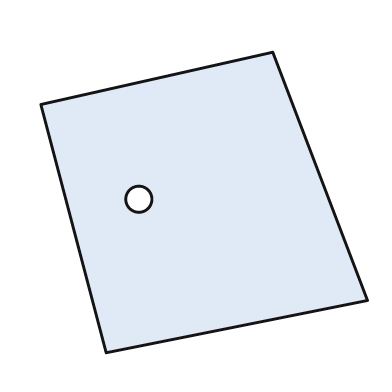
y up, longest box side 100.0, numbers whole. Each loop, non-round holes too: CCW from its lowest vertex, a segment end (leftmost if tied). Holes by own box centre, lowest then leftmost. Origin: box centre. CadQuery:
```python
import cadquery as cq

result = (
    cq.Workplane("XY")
    .moveTo(-30.0, -46.0)
    .lineTo(50.0, -30.0)
    .lineTo(21.0, 46.0)
    .lineTo(-50.0, 30.0)
    .close()
    .moveTo(-20.0, 1.0)
    .circle(4.0)
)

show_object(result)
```